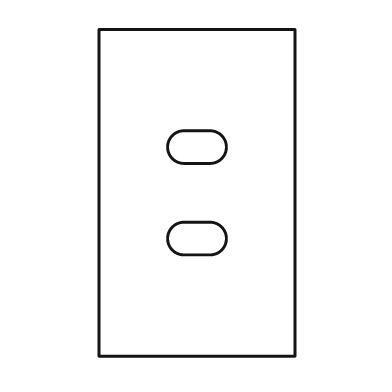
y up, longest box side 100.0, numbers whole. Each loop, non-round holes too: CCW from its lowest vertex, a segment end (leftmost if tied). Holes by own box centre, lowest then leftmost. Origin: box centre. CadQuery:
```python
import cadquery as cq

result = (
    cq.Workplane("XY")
    .moveTo(-30.0, -50.0)
    .lineTo(30.0, -50.0)
    .lineTo(30.0, 50.0)
    .lineTo(-30.0, 50.0)
    .close()
    .moveTo(-4.0, -19.0)
    .lineTo(4.0, -19.0)
    .threePointArc((9.0, -14.0), (4.0, -9.0))
    .lineTo(-4.0, -9.0)
    .threePointArc((-9.0, -14.0), (-4.0, -19.0))
    .close()
    .moveTo(-4.0, 9.0)
    .lineTo(4.0, 9.0)
    .threePointArc((9.0, 14.0), (4.0, 19.0))
    .lineTo(-4.0, 19.0)
    .threePointArc((-9.0, 14.0), (-4.0, 9.0))
    .close()
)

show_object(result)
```